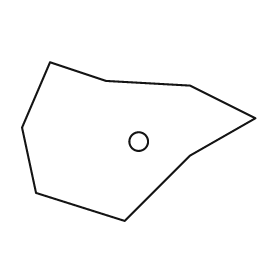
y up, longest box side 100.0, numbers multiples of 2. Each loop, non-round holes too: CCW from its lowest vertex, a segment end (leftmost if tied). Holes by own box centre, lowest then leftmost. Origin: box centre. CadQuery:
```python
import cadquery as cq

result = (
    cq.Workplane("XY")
    .moveTo(-6.0, -34.0)
    .lineTo(22.0, -6.0)
    .lineTo(50.0, 10.0)
    .lineTo(22.0, 24.0)
    .lineTo(-14.0, 26.0)
    .lineTo(-38.0, 34.0)
    .lineTo(-50.0, 6.0)
    .lineTo(-44.0, -22.0)
    .close()
    .moveTo(0.0, 0.0)
    .circle(4.0)
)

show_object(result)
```